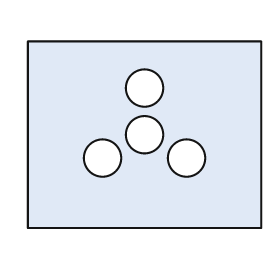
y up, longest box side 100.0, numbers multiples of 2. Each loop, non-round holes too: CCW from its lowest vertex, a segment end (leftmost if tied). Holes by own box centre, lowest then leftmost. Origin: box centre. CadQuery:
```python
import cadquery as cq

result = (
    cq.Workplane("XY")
    .moveTo(-50.0, -40.0)
    .lineTo(50.0, -40.0)
    .lineTo(50.0, 40.0)
    .lineTo(-50.0, 40.0)
    .close()
    .moveTo(-18.0, -10.0)
    .circle(8.0)
    .moveTo(18.0, -10.0)
    .circle(8.0)
    .moveTo(0.0, 0.0)
    .circle(8.0)
    .moveTo(0.0, 20.0)
    .circle(8.0)
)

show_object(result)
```